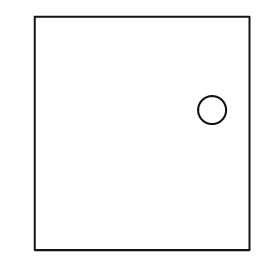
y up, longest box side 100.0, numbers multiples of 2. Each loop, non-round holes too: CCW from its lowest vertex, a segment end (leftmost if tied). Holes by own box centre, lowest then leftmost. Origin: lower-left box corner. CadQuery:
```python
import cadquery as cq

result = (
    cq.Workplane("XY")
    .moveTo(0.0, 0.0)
    .lineTo(92.0, 0.0)
    .lineTo(92.0, 100.0)
    .lineTo(0.0, 100.0)
    .close()
    .moveTo(76.0, 60.0)
    .circle(6.0)
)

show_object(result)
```